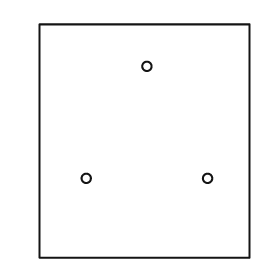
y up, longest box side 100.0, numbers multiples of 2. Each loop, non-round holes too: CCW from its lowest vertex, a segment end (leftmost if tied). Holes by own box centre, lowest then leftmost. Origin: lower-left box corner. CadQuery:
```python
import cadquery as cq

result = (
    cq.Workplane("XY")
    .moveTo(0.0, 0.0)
    .lineTo(90.0, 0.0)
    .lineTo(90.0, 100.0)
    .lineTo(0.0, 100.0)
    .close()
    .moveTo(20.0, 34.0)
    .circle(2.0)
    .moveTo(72.0, 34.0)
    .circle(2.0)
    .moveTo(46.0, 82.0)
    .circle(2.0)
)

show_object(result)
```